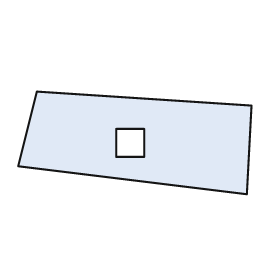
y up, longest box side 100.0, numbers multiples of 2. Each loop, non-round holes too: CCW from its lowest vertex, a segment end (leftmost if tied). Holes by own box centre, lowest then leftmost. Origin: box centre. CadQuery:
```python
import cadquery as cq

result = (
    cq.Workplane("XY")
    .moveTo(48.0, -22.0)
    .lineTo(50.0, 16.0)
    .lineTo(-42.0, 22.0)
    .lineTo(-50.0, -10.0)
    .close()
    .moveTo(-8.0, -6.0)
    .lineTo(4.0, -6.0)
    .lineTo(4.0, 6.0)
    .lineTo(-8.0, 6.0)
    .close()
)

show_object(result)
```